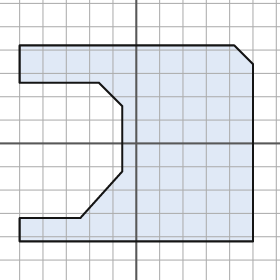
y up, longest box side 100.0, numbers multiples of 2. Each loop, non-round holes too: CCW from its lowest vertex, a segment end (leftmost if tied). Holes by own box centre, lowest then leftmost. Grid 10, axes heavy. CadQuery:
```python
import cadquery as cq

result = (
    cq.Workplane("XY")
    .moveTo(-50.0, -42.0)
    .lineTo(50.0, -42.0)
    .lineTo(50.0, 34.0)
    .lineTo(42.0, 42.0)
    .lineTo(-50.0, 42.0)
    .lineTo(-50.0, 26.0)
    .lineTo(-16.0, 26.0)
    .lineTo(-6.0, 16.0)
    .lineTo(-6.0, -12.0)
    .lineTo(-24.0, -32.0)
    .lineTo(-50.0, -32.0)
    .close()
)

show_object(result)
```